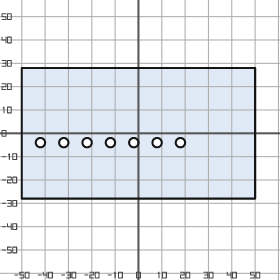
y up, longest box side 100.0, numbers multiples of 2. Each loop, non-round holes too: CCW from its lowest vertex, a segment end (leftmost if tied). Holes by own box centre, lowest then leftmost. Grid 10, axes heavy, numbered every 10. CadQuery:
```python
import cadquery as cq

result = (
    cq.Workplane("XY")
    .moveTo(-50.0, -28.0)
    .lineTo(50.0, -28.0)
    .lineTo(50.0, 28.0)
    .lineTo(-50.0, 28.0)
    .close()
    .moveTo(-42.0, -4.0)
    .circle(2.0)
    .moveTo(-32.0, -4.0)
    .circle(2.0)
    .moveTo(-22.0, -4.0)
    .circle(2.0)
    .moveTo(-12.0, -4.0)
    .circle(2.0)
    .moveTo(-2.0, -4.0)
    .circle(2.0)
    .moveTo(8.0, -4.0)
    .circle(2.0)
    .moveTo(18.0, -4.0)
    .circle(2.0)
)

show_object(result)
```